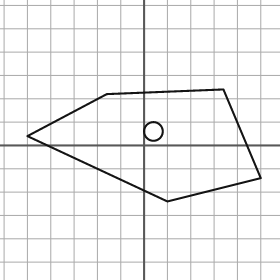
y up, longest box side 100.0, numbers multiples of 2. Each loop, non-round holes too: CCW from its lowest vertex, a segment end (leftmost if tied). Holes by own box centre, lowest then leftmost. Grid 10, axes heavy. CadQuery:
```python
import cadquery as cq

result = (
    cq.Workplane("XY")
    .moveTo(10.0, -24.0)
    .lineTo(50.0, -14.0)
    .lineTo(34.0, 24.0)
    .lineTo(-16.0, 22.0)
    .lineTo(-50.0, 4.0)
    .close()
    .moveTo(4.0, 6.0)
    .circle(4.0)
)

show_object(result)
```